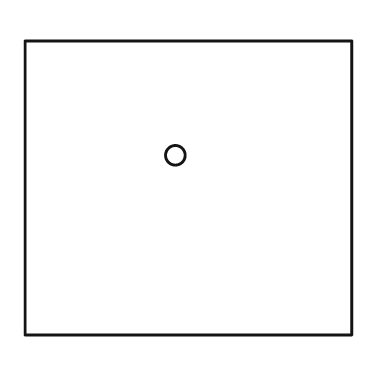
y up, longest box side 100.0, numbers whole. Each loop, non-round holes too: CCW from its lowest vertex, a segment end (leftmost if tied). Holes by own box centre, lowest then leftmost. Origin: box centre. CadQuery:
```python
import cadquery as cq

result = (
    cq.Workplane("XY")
    .moveTo(-50.0, -45.0)
    .lineTo(50.0, -45.0)
    .lineTo(50.0, 45.0)
    .lineTo(-50.0, 45.0)
    .close()
    .moveTo(-4.0, 10.0)
    .circle(3.0)
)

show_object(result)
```